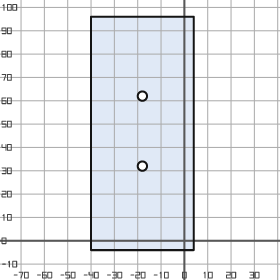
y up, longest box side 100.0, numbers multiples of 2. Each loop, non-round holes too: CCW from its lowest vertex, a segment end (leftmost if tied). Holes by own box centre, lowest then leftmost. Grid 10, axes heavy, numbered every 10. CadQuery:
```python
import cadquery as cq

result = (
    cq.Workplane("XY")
    .moveTo(-40.0, -4.0)
    .lineTo(4.0, -4.0)
    .lineTo(4.0, 96.0)
    .lineTo(-40.0, 96.0)
    .close()
    .moveTo(-18.0, 32.0)
    .circle(2.0)
    .moveTo(-18.0, 62.0)
    .circle(2.0)
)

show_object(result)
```